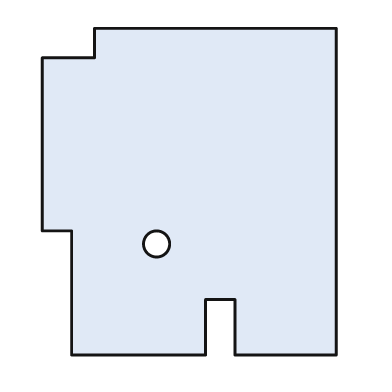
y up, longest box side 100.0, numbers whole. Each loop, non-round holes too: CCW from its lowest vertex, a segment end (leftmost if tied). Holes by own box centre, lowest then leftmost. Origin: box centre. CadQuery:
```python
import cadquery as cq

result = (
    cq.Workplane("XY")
    .moveTo(-36.0, -50.0)
    .lineTo(5.0, -50.0)
    .lineTo(5.0, -33.0)
    .lineTo(14.0, -33.0)
    .lineTo(14.0, -50.0)
    .lineTo(45.0, -50.0)
    .lineTo(45.0, 50.0)
    .lineTo(-29.0, 50.0)
    .lineTo(-29.0, 41.0)
    .lineTo(-45.0, 41.0)
    .lineTo(-45.0, -12.0)
    .lineTo(-36.0, -12.0)
    .close()
    .moveTo(-10.0, -16.0)
    .circle(4.0)
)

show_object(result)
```